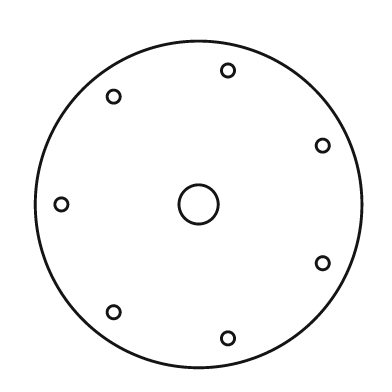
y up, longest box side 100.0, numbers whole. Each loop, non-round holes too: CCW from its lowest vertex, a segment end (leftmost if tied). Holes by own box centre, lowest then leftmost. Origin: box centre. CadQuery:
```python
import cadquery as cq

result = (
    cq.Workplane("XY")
    .moveTo(0.0, 0.0)
    .circle(50.0)
    .moveTo(9.0, -41.0)
    .circle(2.0)
    .moveTo(-26.0, -33.0)
    .circle(2.0)
    .moveTo(38.0, -18.0)
    .circle(2.0)
    .moveTo(-42.0, 0.0)
    .circle(2.0)
    .moveTo(0.0, 0.0)
    .circle(6.0)
    .moveTo(38.0, 18.0)
    .circle(2.0)
    .moveTo(-26.0, 33.0)
    .circle(2.0)
    .moveTo(9.0, 41.0)
    .circle(2.0)
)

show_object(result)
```